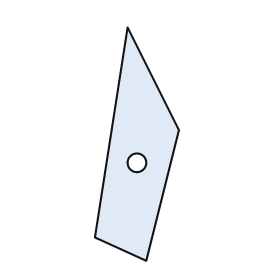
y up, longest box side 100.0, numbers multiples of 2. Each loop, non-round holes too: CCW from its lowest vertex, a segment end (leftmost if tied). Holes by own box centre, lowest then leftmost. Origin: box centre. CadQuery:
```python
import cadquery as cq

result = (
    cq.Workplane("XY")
    .moveTo(4.0, -50.0)
    .lineTo(18.0, 6.0)
    .lineTo(-4.0, 50.0)
    .lineTo(-18.0, -40.0)
    .close()
    .moveTo(0.0, -8.0)
    .circle(4.0)
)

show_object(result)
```